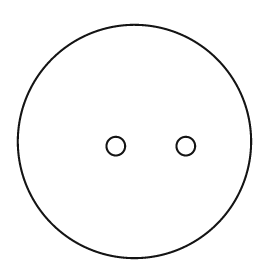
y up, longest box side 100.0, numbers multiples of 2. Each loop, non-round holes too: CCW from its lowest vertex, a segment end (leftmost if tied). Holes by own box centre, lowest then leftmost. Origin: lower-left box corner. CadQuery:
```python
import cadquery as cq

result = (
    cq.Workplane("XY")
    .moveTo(50.0, 50.0)
    .circle(50.0)
    .moveTo(42.0, 48.0)
    .circle(4.0)
    .moveTo(72.0, 48.0)
    .circle(4.0)
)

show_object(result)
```